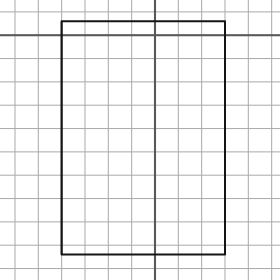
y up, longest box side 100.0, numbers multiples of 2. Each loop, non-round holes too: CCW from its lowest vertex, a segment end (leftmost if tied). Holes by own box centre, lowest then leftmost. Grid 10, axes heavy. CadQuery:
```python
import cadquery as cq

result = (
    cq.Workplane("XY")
    .moveTo(-40.0, -94.0)
    .lineTo(30.0, -94.0)
    .lineTo(30.0, 6.0)
    .lineTo(-40.0, 6.0)
    .close()
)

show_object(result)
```